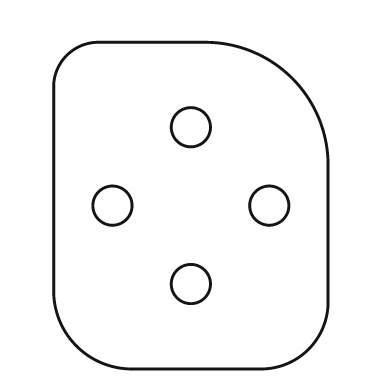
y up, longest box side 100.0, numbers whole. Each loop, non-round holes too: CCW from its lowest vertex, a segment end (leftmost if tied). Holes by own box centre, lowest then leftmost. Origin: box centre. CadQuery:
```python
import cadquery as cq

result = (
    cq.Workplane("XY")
    .moveTo(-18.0, -50.0)
    .lineTo(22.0, -50.0)
    .threePointArc((36.0, -44.0), (42.0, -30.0))
    .lineTo(42.0, 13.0)
    .threePointArc((31.0, 39.0), (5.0, 50.0))
    .lineTo(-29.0, 50.0)
    .threePointArc((-38.0, 46.0), (-42.0, 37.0))
    .lineTo(-42.0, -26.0)
    .threePointArc((-35.0, -43.0), (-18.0, -50.0))
    .close()
    .moveTo(0.0, -24.0)
    .circle(6.0)
    .moveTo(-24.0, 0.0)
    .circle(6.0)
    .moveTo(24.0, 0.0)
    .circle(6.0)
    .moveTo(0.0, 24.0)
    .circle(6.0)
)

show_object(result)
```